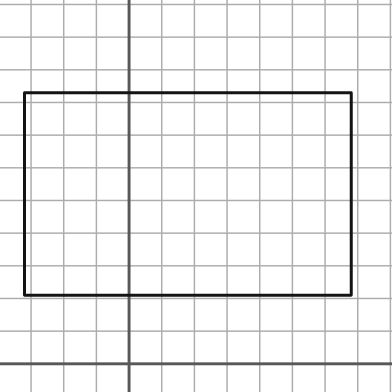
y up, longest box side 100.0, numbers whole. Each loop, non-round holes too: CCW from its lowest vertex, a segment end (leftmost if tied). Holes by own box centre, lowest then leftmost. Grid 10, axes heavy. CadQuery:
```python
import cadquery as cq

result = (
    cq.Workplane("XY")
    .moveTo(-32.0, 21.0)
    .lineTo(68.0, 21.0)
    .lineTo(68.0, 83.0)
    .lineTo(-32.0, 83.0)
    .close()
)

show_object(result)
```